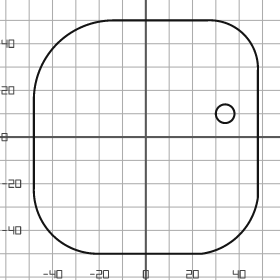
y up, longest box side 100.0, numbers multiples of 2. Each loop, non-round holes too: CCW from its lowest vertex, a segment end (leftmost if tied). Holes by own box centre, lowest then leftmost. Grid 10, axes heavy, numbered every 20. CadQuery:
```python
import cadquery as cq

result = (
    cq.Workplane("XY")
    .moveTo(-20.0, -50.0)
    .lineTo(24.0, -50.0)
    .threePointArc((40.0, -42.0), (48.0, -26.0))
    .lineTo(48.0, 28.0)
    .threePointArc((42.0, 44.0), (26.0, 50.0))
    .lineTo(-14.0, 50.0)
    .threePointArc((-38.0, 40.0), (-48.0, 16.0))
    .lineTo(-48.0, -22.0)
    .threePointArc((-40.0, -42.0), (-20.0, -50.0))
    .close()
    .moveTo(34.0, 10.0)
    .circle(4.0)
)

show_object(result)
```